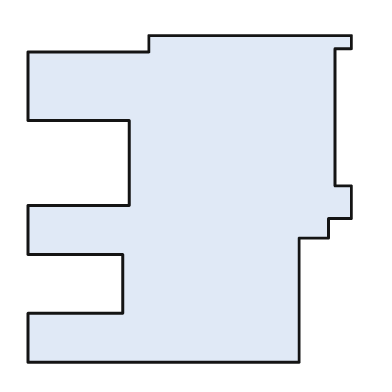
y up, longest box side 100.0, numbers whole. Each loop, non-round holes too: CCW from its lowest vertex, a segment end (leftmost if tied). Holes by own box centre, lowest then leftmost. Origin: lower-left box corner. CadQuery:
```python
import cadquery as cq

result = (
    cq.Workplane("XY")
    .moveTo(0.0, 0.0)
    .lineTo(83.0, 0.0)
    .lineTo(83.0, 38.0)
    .lineTo(92.0, 38.0)
    .lineTo(92.0, 44.0)
    .lineTo(99.0, 44.0)
    .lineTo(99.0, 54.0)
    .lineTo(94.0, 54.0)
    .lineTo(94.0, 96.0)
    .lineTo(99.0, 96.0)
    .lineTo(99.0, 100.0)
    .lineTo(37.0, 100.0)
    .lineTo(37.0, 95.0)
    .lineTo(0.0, 95.0)
    .lineTo(0.0, 74.0)
    .lineTo(31.0, 74.0)
    .lineTo(31.0, 48.0)
    .lineTo(0.0, 48.0)
    .lineTo(0.0, 33.0)
    .lineTo(29.0, 33.0)
    .lineTo(29.0, 15.0)
    .lineTo(0.0, 15.0)
    .close()
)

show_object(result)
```